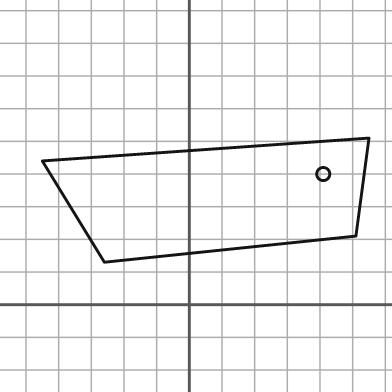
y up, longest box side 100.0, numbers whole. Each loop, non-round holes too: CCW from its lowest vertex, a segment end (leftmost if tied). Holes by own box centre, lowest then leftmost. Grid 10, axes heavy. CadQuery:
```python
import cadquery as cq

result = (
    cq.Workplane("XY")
    .moveTo(-26.0, 13.0)
    .lineTo(51.0, 21.0)
    .lineTo(55.0, 51.0)
    .lineTo(-45.0, 44.0)
    .close()
    .moveTo(41.0, 40.0)
    .circle(2.0)
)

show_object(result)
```